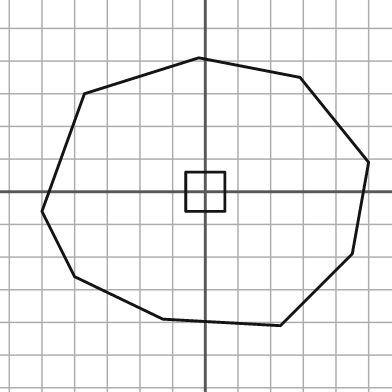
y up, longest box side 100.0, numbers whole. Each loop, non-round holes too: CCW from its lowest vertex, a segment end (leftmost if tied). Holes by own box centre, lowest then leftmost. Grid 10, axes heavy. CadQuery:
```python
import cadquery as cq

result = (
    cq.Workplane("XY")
    .moveTo(23.0, -41.0)
    .lineTo(45.0, -19.0)
    .lineTo(50.0, 9.0)
    .lineTo(29.0, 35.0)
    .lineTo(-2.0, 41.0)
    .lineTo(-37.0, 30.0)
    .lineTo(-50.0, -6.0)
    .lineTo(-40.0, -26.0)
    .lineTo(-13.0, -39.0)
    .close()
    .moveTo(-6.0, -6.0)
    .lineTo(6.0, -6.0)
    .lineTo(6.0, 6.0)
    .lineTo(-6.0, 6.0)
    .close()
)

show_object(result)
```